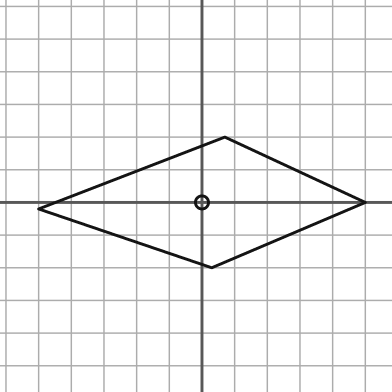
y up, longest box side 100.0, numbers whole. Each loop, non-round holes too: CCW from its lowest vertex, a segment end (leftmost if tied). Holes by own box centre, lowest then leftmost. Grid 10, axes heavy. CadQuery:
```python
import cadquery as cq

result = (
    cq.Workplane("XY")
    .moveTo(3.0, -20.0)
    .lineTo(50.0, 0.0)
    .lineTo(7.0, 20.0)
    .lineTo(-50.0, -2.0)
    .close()
    .moveTo(0.0, 0.0)
    .circle(2.0)
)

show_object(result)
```